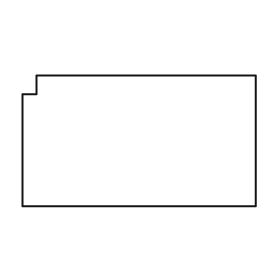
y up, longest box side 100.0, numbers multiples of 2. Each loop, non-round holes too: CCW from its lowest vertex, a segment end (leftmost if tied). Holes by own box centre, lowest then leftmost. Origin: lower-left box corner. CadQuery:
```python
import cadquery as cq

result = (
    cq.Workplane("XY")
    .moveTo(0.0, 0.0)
    .lineTo(100.0, 0.0)
    .lineTo(100.0, 56.0)
    .lineTo(6.0, 56.0)
    .lineTo(6.0, 48.0)
    .lineTo(0.0, 48.0)
    .close()
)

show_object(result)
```